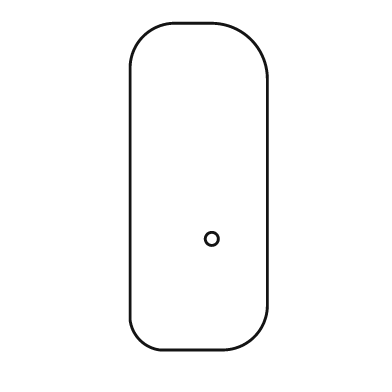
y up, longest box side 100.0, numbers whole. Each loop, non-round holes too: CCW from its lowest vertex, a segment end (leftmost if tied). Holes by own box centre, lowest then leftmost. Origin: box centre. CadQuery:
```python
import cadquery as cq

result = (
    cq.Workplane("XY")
    .moveTo(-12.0, -50.0)
    .lineTo(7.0, -50.0)
    .threePointArc((17.0, -46.0), (21.0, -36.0))
    .lineTo(21.0, 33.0)
    .threePointArc((16.0, 45.0), (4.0, 50.0))
    .lineTo(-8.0, 50.0)
    .threePointArc((-17.0, 46.0), (-21.0, 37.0))
    .lineTo(-21.0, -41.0)
    .threePointArc((-18.0, -47.0), (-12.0, -50.0))
    .close()
    .moveTo(4.0, -16.0)
    .circle(2.0)
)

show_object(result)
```